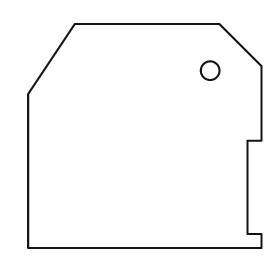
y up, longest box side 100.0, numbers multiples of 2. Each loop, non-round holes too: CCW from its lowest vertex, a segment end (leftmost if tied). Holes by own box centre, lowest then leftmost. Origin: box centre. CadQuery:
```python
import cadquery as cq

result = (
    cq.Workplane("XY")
    .moveTo(-50.0, -48.0)
    .lineTo(50.0, -48.0)
    .lineTo(50.0, -42.0)
    .lineTo(44.0, -42.0)
    .lineTo(44.0, -2.0)
    .lineTo(50.0, -2.0)
    .lineTo(50.0, 30.0)
    .lineTo(32.0, 48.0)
    .lineTo(-30.0, 48.0)
    .lineTo(-50.0, 18.0)
    .close()
    .moveTo(28.0, 28.0)
    .circle(4.0)
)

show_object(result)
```